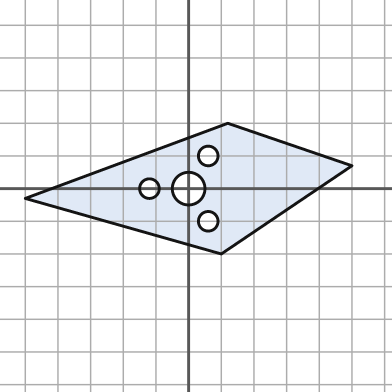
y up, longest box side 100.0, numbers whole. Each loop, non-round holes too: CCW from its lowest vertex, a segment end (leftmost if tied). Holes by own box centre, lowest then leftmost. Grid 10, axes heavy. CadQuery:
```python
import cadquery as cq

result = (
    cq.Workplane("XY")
    .moveTo(10.0, -20.0)
    .lineTo(50.0, 7.0)
    .lineTo(12.0, 20.0)
    .lineTo(-50.0, -3.0)
    .close()
    .moveTo(6.0, -10.0)
    .circle(3.0)
    .moveTo(-12.0, 0.0)
    .circle(3.0)
    .moveTo(0.0, 0.0)
    .circle(5.0)
    .moveTo(6.0, 10.0)
    .circle(3.0)
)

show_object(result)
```